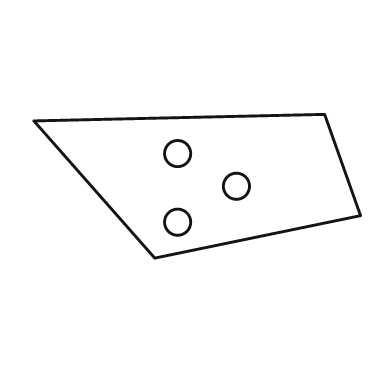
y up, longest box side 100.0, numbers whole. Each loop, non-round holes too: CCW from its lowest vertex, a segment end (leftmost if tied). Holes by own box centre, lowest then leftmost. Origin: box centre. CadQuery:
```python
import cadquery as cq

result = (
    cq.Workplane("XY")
    .moveTo(-13.0, -22.0)
    .lineTo(50.0, -9.0)
    .lineTo(39.0, 22.0)
    .lineTo(-50.0, 20.0)
    .close()
    .moveTo(-6.0, -11.0)
    .circle(4.0)
    .moveTo(12.0, 0.0)
    .circle(4.0)
    .moveTo(-6.0, 10.0)
    .circle(4.0)
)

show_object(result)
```